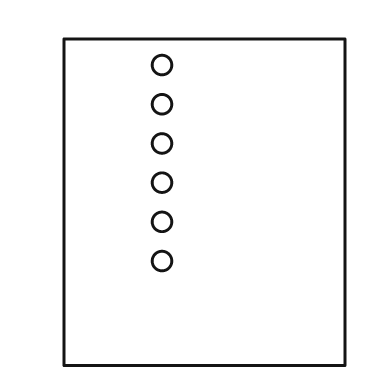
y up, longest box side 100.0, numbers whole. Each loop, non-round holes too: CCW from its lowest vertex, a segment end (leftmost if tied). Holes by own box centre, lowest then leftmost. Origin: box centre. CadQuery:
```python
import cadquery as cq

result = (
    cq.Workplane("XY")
    .moveTo(-43.0, -50.0)
    .lineTo(43.0, -50.0)
    .lineTo(43.0, 50.0)
    .lineTo(-43.0, 50.0)
    .close()
    .moveTo(-13.0, -18.0)
    .circle(3.0)
    .moveTo(-13.0, -6.0)
    .circle(3.0)
    .moveTo(-13.0, 6.0)
    .circle(3.0)
    .moveTo(-13.0, 18.0)
    .circle(3.0)
    .moveTo(-13.0, 30.0)
    .circle(3.0)
    .moveTo(-13.0, 42.0)
    .circle(3.0)
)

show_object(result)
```